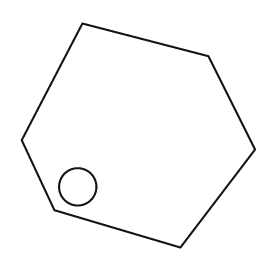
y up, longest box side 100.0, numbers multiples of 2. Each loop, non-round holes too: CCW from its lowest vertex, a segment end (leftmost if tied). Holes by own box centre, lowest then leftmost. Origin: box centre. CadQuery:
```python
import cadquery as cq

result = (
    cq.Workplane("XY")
    .moveTo(18.0, -48.0)
    .lineTo(50.0, -6.0)
    .lineTo(30.0, 34.0)
    .lineTo(-24.0, 48.0)
    .lineTo(-50.0, -2.0)
    .lineTo(-36.0, -32.0)
    .close()
    .moveTo(-26.0, -22.0)
    .circle(8.0)
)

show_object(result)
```